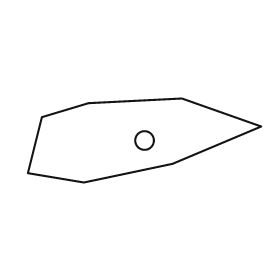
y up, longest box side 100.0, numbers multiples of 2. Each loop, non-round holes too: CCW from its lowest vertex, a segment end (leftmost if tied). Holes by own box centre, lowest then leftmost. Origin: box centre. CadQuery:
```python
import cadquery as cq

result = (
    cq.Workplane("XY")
    .moveTo(-26.0, -18.0)
    .lineTo(12.0, -10.0)
    .lineTo(50.0, 6.0)
    .lineTo(16.0, 18.0)
    .lineTo(-24.0, 16.0)
    .lineTo(-44.0, 10.0)
    .lineTo(-50.0, -14.0)
    .close()
    .moveTo(0.0, 0.0)
    .circle(4.0)
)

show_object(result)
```